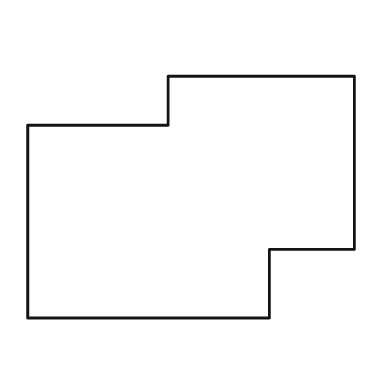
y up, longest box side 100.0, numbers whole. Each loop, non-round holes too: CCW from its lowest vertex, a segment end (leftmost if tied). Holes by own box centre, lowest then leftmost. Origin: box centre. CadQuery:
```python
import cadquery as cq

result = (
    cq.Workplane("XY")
    .moveTo(-50.0, -37.0)
    .lineTo(24.0, -37.0)
    .lineTo(24.0, -16.0)
    .lineTo(50.0, -16.0)
    .lineTo(50.0, 37.0)
    .lineTo(-7.0, 37.0)
    .lineTo(-7.0, 22.0)
    .lineTo(-50.0, 22.0)
    .close()
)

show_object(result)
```